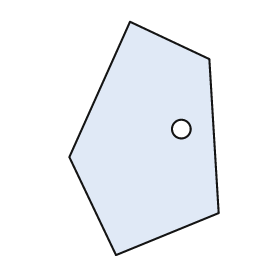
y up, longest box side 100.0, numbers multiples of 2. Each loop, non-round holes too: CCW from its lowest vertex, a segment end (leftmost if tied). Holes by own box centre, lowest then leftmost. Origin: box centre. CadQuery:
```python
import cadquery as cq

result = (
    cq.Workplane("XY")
    .moveTo(-12.0, -50.0)
    .lineTo(32.0, -32.0)
    .lineTo(28.0, 34.0)
    .lineTo(-6.0, 50.0)
    .lineTo(-32.0, -8.0)
    .close()
    .moveTo(16.0, 4.0)
    .circle(4.0)
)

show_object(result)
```